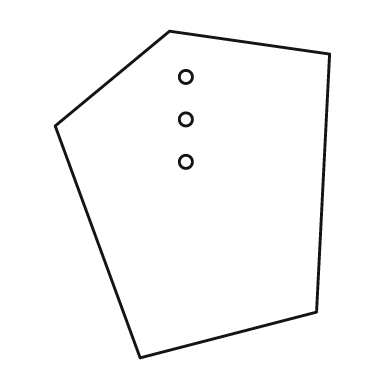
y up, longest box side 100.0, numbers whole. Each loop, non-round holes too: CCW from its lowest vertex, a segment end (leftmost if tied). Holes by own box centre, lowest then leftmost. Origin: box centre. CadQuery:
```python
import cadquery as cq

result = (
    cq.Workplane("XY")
    .moveTo(-16.0, -50.0)
    .lineTo(38.0, -36.0)
    .lineTo(42.0, 43.0)
    .lineTo(-7.0, 50.0)
    .lineTo(-42.0, 21.0)
    .close()
    .moveTo(-2.0, 10.0)
    .circle(2.0)
    .moveTo(-2.0, 23.0)
    .circle(2.0)
    .moveTo(-2.0, 36.0)
    .circle(2.0)
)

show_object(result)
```